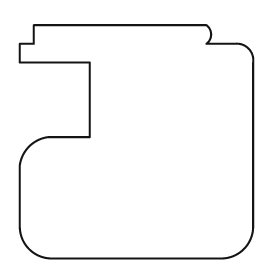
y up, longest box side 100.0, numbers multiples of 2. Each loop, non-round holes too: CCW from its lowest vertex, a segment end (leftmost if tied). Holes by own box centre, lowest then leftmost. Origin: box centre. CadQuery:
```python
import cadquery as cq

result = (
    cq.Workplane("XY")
    .moveTo(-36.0, -50.0)
    .lineTo(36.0, -50.0)
    .threePointArc((46.0, -46.0), (50.0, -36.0))
    .lineTo(50.0, 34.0)
    .threePointArc((48.0, 40.0), (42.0, 42.0))
    .lineTo(30.0, 42.0)
    .threePointArc((32.0, 46.0), (30.0, 50.0))
    .lineTo(-44.0, 50.0)
    .lineTo(-44.0, 42.0)
    .lineTo(-50.0, 42.0)
    .lineTo(-50.0, 34.0)
    .lineTo(-20.0, 34.0)
    .lineTo(-20.0, 2.0)
    .lineTo(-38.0, 2.0)
    .threePointArc((-46.0, -2.0), (-50.0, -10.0))
    .lineTo(-50.0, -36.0)
    .threePointArc((-46.0, -46.0), (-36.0, -50.0))
    .close()
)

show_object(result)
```